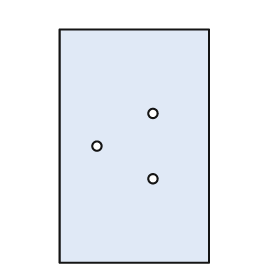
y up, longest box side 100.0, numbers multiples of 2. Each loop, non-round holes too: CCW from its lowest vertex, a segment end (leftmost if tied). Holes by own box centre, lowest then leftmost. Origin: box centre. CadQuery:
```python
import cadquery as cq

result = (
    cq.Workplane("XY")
    .moveTo(-32.0, -50.0)
    .lineTo(32.0, -50.0)
    .lineTo(32.0, 50.0)
    .lineTo(-32.0, 50.0)
    .close()
    .moveTo(8.0, -14.0)
    .circle(2.0)
    .moveTo(-16.0, 0.0)
    .circle(2.0)
    .moveTo(8.0, 14.0)
    .circle(2.0)
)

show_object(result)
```